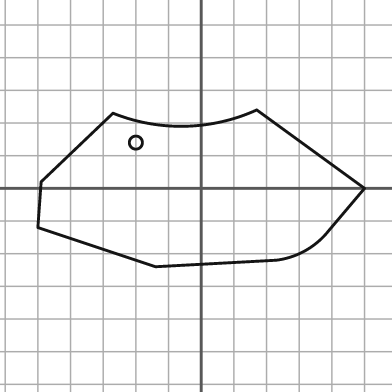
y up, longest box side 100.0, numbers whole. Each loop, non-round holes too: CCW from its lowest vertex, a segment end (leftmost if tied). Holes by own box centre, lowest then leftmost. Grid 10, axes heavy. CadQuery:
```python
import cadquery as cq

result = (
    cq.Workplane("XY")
    .moveTo(-14.0, -24.0)
    .lineTo(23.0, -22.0)
    .threePointArc((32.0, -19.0), (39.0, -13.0))
    .lineTo(50.0, 0.0)
    .lineTo(17.0, 24.0)
    .threePointArc((-5.0, 19.0), (-27.0, 23.0))
    .lineTo(-49.0, 2.0)
    .lineTo(-50.0, -12.0)
    .close()
    .moveTo(-20.0, 14.0)
    .circle(2.0)
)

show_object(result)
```